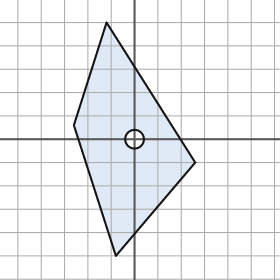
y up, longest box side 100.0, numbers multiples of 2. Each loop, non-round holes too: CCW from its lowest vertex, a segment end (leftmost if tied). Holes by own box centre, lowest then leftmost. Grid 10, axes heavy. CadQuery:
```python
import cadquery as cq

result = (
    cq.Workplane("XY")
    .moveTo(-8.0, -50.0)
    .lineTo(26.0, -10.0)
    .lineTo(-12.0, 50.0)
    .lineTo(-26.0, 6.0)
    .close()
    .moveTo(0.0, 0.0)
    .circle(4.0)
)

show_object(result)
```